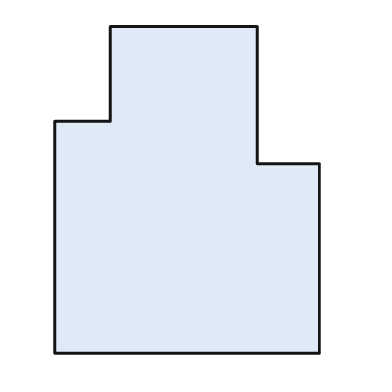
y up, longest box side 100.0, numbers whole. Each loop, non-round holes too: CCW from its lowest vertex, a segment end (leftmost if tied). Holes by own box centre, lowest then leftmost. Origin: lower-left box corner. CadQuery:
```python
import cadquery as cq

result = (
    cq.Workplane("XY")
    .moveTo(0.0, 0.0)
    .lineTo(81.0, 0.0)
    .lineTo(81.0, 58.0)
    .lineTo(62.0, 58.0)
    .lineTo(62.0, 100.0)
    .lineTo(17.0, 100.0)
    .lineTo(17.0, 71.0)
    .lineTo(0.0, 71.0)
    .close()
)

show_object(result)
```